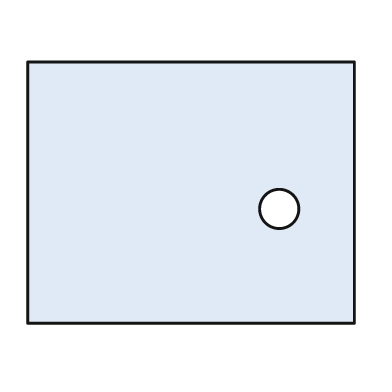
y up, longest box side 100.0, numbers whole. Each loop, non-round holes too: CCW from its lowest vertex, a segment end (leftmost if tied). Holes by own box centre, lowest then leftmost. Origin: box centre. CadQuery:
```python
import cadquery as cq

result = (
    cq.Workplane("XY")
    .moveTo(-50.0, -40.0)
    .lineTo(50.0, -40.0)
    .lineTo(50.0, 40.0)
    .lineTo(-50.0, 40.0)
    .close()
    .moveTo(27.0, -5.0)
    .circle(6.0)
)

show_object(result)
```